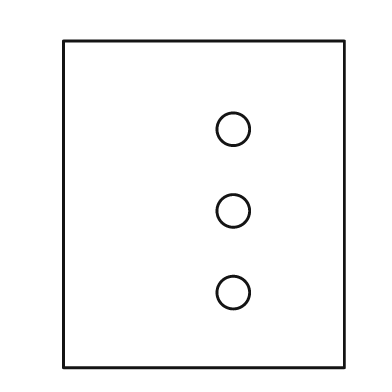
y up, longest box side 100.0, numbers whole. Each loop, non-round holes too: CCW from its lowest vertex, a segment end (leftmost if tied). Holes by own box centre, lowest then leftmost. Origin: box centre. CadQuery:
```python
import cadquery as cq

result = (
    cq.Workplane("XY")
    .moveTo(-43.0, -50.0)
    .lineTo(43.0, -50.0)
    .lineTo(43.0, 50.0)
    .lineTo(-43.0, 50.0)
    .close()
    .moveTo(9.0, -27.0)
    .circle(5.0)
    .moveTo(9.0, -2.0)
    .circle(5.0)
    .moveTo(9.0, 23.0)
    .circle(5.0)
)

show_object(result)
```